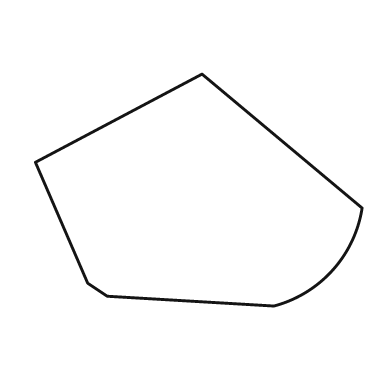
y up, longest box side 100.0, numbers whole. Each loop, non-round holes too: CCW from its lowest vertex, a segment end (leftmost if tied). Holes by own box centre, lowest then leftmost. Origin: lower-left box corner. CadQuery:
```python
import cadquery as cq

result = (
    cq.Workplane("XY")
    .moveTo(73.0, 0.0)
    .threePointArc((91.0, 11.0), (100.0, 30.0))
    .lineTo(51.0, 71.0)
    .lineTo(0.0, 44.0)
    .lineTo(16.0, 7.0)
    .lineTo(22.0, 3.0)
    .close()
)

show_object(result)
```